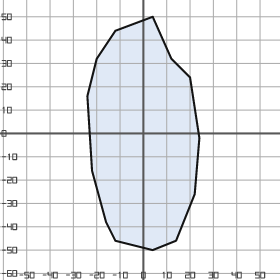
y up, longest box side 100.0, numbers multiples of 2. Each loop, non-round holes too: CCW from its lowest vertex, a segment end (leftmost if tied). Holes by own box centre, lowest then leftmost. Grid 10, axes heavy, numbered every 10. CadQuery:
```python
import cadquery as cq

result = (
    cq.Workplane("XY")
    .moveTo(4.0, -50.0)
    .lineTo(14.0, -46.0)
    .lineTo(22.0, -26.0)
    .lineTo(24.0, -2.0)
    .lineTo(20.0, 24.0)
    .lineTo(12.0, 32.0)
    .lineTo(4.0, 50.0)
    .lineTo(-12.0, 44.0)
    .lineTo(-20.0, 32.0)
    .lineTo(-24.0, 16.0)
    .lineTo(-22.0, -16.0)
    .lineTo(-16.0, -38.0)
    .lineTo(-12.0, -46.0)
    .close()
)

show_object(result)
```